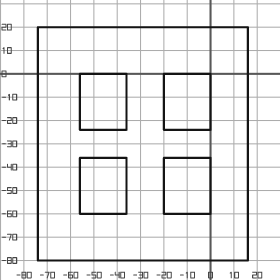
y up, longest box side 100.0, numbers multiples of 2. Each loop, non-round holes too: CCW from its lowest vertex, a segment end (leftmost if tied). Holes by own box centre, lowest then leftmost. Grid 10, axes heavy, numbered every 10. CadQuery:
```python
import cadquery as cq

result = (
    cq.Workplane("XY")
    .moveTo(-74.0, -80.0)
    .lineTo(16.0, -80.0)
    .lineTo(16.0, 20.0)
    .lineTo(-74.0, 20.0)
    .close()
    .moveTo(-56.0, -60.0)
    .lineTo(-36.0, -60.0)
    .lineTo(-36.0, -36.0)
    .lineTo(-56.0, -36.0)
    .close()
    .moveTo(-20.0, -60.0)
    .lineTo(0.0, -60.0)
    .lineTo(0.0, -36.0)
    .lineTo(-20.0, -36.0)
    .close()
    .moveTo(-56.0, -24.0)
    .lineTo(-36.0, -24.0)
    .lineTo(-36.0, 0.0)
    .lineTo(-56.0, 0.0)
    .close()
    .moveTo(-20.0, -24.0)
    .lineTo(0.0, -24.0)
    .lineTo(0.0, 0.0)
    .lineTo(-20.0, 0.0)
    .close()
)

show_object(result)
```